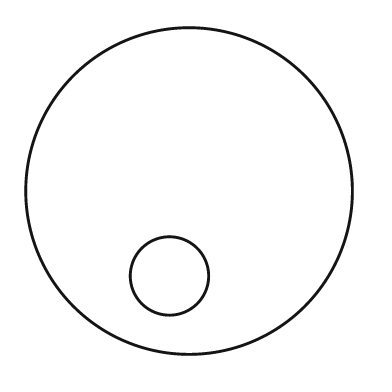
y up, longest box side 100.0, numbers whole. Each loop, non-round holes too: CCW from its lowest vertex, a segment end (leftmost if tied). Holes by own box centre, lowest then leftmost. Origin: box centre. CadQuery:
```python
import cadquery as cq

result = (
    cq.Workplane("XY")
    .moveTo(0.0, 0.0)
    .circle(50.0)
    .moveTo(-6.0, -26.0)
    .circle(12.0)
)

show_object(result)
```